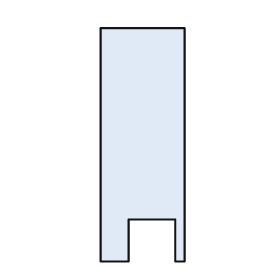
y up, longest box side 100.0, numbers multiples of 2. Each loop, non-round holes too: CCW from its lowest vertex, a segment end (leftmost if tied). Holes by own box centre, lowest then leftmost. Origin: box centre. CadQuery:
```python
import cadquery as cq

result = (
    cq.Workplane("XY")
    .moveTo(-18.0, -50.0)
    .lineTo(-6.0, -50.0)
    .lineTo(-6.0, -32.0)
    .lineTo(14.0, -32.0)
    .lineTo(14.0, -50.0)
    .lineTo(18.0, -50.0)
    .lineTo(18.0, 50.0)
    .lineTo(-18.0, 50.0)
    .close()
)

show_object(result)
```